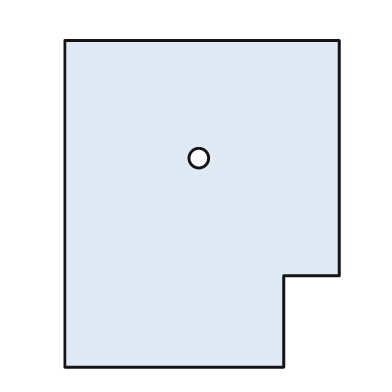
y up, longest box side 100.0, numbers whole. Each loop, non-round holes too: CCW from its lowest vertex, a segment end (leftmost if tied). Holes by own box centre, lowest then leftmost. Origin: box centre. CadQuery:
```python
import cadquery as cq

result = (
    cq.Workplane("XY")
    .moveTo(-42.0, -50.0)
    .lineTo(25.0, -50.0)
    .lineTo(25.0, -22.0)
    .lineTo(42.0, -22.0)
    .lineTo(42.0, 50.0)
    .lineTo(-42.0, 50.0)
    .close()
    .moveTo(-1.0, 14.0)
    .circle(3.0)
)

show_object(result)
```